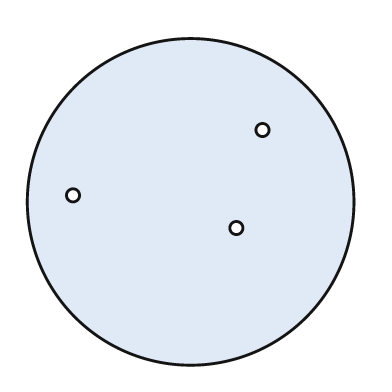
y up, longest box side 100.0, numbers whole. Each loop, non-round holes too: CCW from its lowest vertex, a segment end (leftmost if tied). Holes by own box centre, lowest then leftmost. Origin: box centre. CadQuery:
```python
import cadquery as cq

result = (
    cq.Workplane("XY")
    .moveTo(0.0, 0.0)
    .circle(50.0)
    .moveTo(14.0, -8.0)
    .circle(2.0)
    .moveTo(-36.0, 2.0)
    .circle(2.0)
    .moveTo(22.0, 22.0)
    .circle(2.0)
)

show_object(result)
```